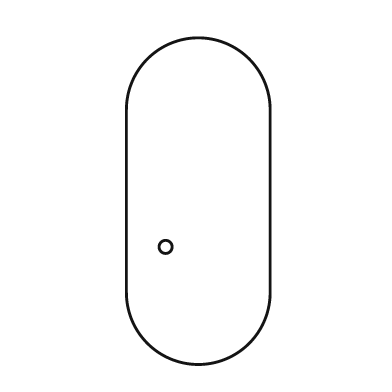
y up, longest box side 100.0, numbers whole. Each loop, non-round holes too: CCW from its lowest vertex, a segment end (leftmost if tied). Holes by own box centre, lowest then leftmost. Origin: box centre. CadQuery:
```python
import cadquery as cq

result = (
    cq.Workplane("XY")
    .moveTo(-22.0, -28.0)
    .threePointArc((0.0, -50.0), (22.0, -28.0))
    .lineTo(22.0, 28.0)
    .threePointArc((0.0, 50.0), (-22.0, 28.0))
    .close()
    .moveTo(-10.0, -14.0)
    .circle(2.0)
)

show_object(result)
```